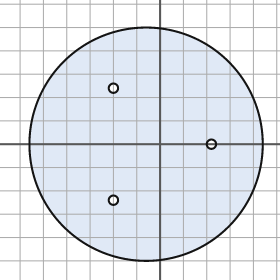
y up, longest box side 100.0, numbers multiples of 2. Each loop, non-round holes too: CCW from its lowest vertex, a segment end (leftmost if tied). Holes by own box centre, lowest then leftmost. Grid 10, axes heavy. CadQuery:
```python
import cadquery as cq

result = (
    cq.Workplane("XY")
    .moveTo(-6.0, 0.0)
    .circle(50.0)
    .moveTo(-20.0, -24.0)
    .circle(2.0)
    .moveTo(22.0, 0.0)
    .circle(2.0)
    .moveTo(-20.0, 24.0)
    .circle(2.0)
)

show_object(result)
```